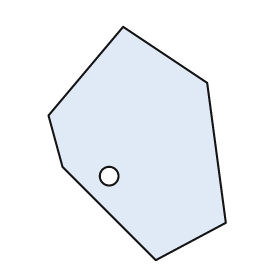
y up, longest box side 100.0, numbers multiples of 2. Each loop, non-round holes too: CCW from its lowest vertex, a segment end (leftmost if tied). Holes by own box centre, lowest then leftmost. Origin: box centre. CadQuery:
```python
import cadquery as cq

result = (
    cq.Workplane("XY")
    .moveTo(8.0, -50.0)
    .lineTo(38.0, -34.0)
    .lineTo(30.0, 26.0)
    .lineTo(-6.0, 50.0)
    .lineTo(-38.0, 12.0)
    .lineTo(-32.0, -10.0)
    .close()
    .moveTo(-12.0, -14.0)
    .circle(4.0)
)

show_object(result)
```